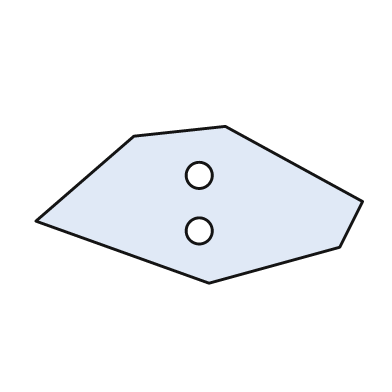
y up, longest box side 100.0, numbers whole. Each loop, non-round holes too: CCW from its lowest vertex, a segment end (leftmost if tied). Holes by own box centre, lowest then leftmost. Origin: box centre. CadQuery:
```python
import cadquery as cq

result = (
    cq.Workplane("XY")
    .moveTo(3.0, -24.0)
    .lineTo(43.0, -13.0)
    .lineTo(50.0, 1.0)
    .lineTo(8.0, 24.0)
    .lineTo(-20.0, 21.0)
    .lineTo(-50.0, -5.0)
    .close()
    .moveTo(0.0, -8.0)
    .circle(4.0)
    .moveTo(0.0, 9.0)
    .circle(4.0)
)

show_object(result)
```